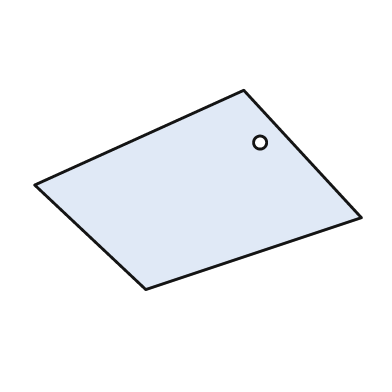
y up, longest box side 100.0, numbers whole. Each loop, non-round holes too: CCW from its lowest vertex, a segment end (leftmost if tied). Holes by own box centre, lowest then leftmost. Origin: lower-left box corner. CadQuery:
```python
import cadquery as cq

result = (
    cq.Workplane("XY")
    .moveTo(34.0, 0.0)
    .lineTo(100.0, 22.0)
    .lineTo(64.0, 61.0)
    .lineTo(0.0, 32.0)
    .close()
    .moveTo(69.0, 45.0)
    .circle(2.0)
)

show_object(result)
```